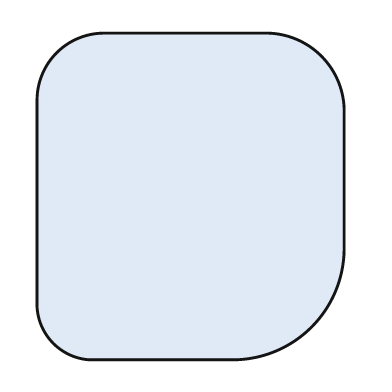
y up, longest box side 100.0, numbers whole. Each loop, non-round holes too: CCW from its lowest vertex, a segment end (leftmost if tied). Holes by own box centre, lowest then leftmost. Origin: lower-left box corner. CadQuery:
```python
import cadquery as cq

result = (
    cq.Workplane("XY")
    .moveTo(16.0, 0.0)
    .lineTo(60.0, 0.0)
    .threePointArc((84.0, 10.0), (94.0, 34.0))
    .lineTo(94.0, 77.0)
    .threePointArc((87.0, 93.0), (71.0, 100.0))
    .lineTo(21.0, 100.0)
    .threePointArc((6.0, 94.0), (0.0, 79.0))
    .lineTo(0.0, 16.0)
    .threePointArc((5.0, 5.0), (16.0, 0.0))
    .close()
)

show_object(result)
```